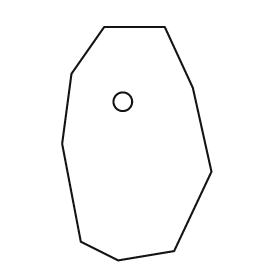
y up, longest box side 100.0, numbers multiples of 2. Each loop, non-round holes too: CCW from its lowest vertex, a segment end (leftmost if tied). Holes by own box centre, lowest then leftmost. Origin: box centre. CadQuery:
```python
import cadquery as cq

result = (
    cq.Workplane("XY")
    .moveTo(-8.0, -50.0)
    .lineTo(16.0, -46.0)
    .lineTo(32.0, -12.0)
    .lineTo(24.0, 24.0)
    .lineTo(12.0, 50.0)
    .lineTo(-14.0, 50.0)
    .lineTo(-28.0, 30.0)
    .lineTo(-32.0, 0.0)
    .lineTo(-24.0, -42.0)
    .close()
    .moveTo(-6.0, 18.0)
    .circle(4.0)
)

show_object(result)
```